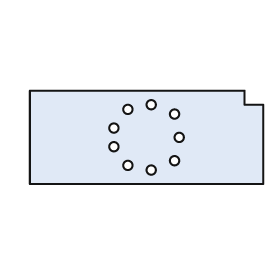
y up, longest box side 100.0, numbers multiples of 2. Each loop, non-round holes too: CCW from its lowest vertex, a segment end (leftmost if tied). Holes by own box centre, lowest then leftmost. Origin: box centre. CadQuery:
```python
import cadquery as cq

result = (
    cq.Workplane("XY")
    .moveTo(-50.0, -20.0)
    .lineTo(50.0, -20.0)
    .lineTo(50.0, 14.0)
    .lineTo(42.0, 14.0)
    .lineTo(42.0, 20.0)
    .lineTo(-50.0, 20.0)
    .close()
    .moveTo(2.0, -14.0)
    .circle(2.0)
    .moveTo(-8.0, -12.0)
    .circle(2.0)
    .moveTo(12.0, -10.0)
    .circle(2.0)
    .moveTo(-14.0, -4.0)
    .circle(2.0)
    .moveTo(14.0, 0.0)
    .circle(2.0)
    .moveTo(-14.0, 4.0)
    .circle(2.0)
    .moveTo(12.0, 10.0)
    .circle(2.0)
    .moveTo(-8.0, 12.0)
    .circle(2.0)
    .moveTo(2.0, 14.0)
    .circle(2.0)
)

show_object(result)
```